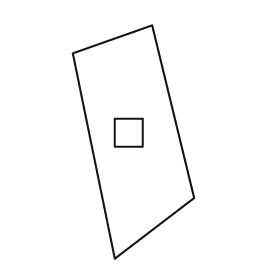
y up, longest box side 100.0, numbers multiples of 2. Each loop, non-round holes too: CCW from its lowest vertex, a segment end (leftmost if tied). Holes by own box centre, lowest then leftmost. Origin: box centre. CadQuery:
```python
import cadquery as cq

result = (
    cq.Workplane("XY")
    .moveTo(-8.0, -50.0)
    .lineTo(26.0, -24.0)
    .lineTo(8.0, 50.0)
    .lineTo(-26.0, 38.0)
    .close()
    .moveTo(-8.0, -2.0)
    .lineTo(4.0, -2.0)
    .lineTo(4.0, 10.0)
    .lineTo(-8.0, 10.0)
    .close()
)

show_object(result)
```